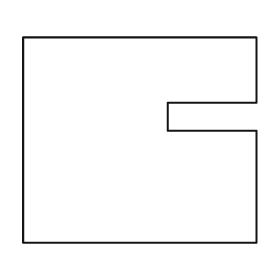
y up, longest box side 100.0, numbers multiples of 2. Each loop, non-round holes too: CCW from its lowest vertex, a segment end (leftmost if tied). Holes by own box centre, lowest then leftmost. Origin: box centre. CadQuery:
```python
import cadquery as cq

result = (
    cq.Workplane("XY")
    .moveTo(-50.0, -44.0)
    .lineTo(50.0, -44.0)
    .lineTo(50.0, 4.0)
    .lineTo(12.0, 4.0)
    .lineTo(12.0, 16.0)
    .lineTo(50.0, 16.0)
    .lineTo(50.0, 44.0)
    .lineTo(-50.0, 44.0)
    .close()
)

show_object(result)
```